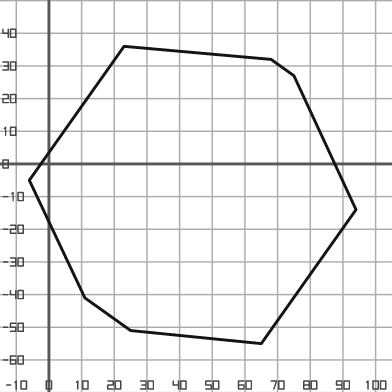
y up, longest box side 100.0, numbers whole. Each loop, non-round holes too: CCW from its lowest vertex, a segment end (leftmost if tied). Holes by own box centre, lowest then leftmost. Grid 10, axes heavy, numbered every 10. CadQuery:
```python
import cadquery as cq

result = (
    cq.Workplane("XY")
    .moveTo(65.0, -55.0)
    .lineTo(94.0, -14.0)
    .lineTo(75.0, 27.0)
    .lineTo(68.0, 32.0)
    .lineTo(23.0, 36.0)
    .lineTo(-6.0, -5.0)
    .lineTo(11.0, -41.0)
    .lineTo(25.0, -51.0)
    .close()
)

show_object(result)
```